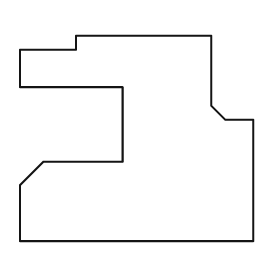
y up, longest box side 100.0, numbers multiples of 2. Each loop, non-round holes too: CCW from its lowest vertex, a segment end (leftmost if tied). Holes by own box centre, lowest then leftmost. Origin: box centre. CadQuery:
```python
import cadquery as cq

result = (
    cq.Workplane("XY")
    .moveTo(-50.0, -44.0)
    .lineTo(50.0, -44.0)
    .lineTo(50.0, 8.0)
    .lineTo(38.0, 8.0)
    .lineTo(32.0, 14.0)
    .lineTo(32.0, 44.0)
    .lineTo(-26.0, 44.0)
    .lineTo(-26.0, 38.0)
    .lineTo(-50.0, 38.0)
    .lineTo(-50.0, 22.0)
    .lineTo(-6.0, 22.0)
    .lineTo(-6.0, -10.0)
    .lineTo(-40.0, -10.0)
    .lineTo(-50.0, -20.0)
    .close()
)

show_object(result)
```